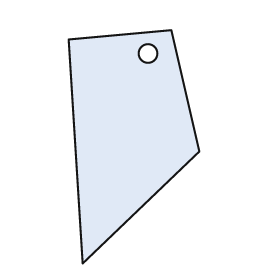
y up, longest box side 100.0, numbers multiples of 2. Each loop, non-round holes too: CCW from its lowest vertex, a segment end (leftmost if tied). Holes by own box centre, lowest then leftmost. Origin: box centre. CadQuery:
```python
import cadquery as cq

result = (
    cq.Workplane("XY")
    .moveTo(-22.0, -50.0)
    .lineTo(28.0, -2.0)
    .lineTo(16.0, 50.0)
    .lineTo(-28.0, 46.0)
    .close()
    .moveTo(6.0, 40.0)
    .circle(4.0)
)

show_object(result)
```